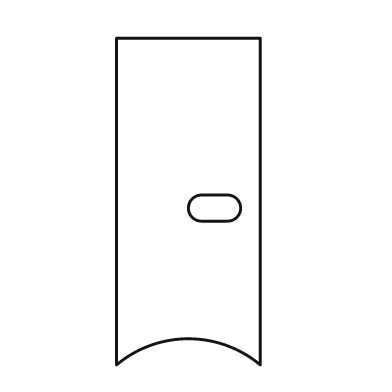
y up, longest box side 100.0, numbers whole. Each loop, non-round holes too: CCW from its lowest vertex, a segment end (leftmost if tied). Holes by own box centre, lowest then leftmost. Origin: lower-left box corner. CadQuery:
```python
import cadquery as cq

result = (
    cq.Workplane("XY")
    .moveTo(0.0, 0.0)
    .threePointArc((22.0, 8.0), (44.0, 0.0))
    .lineTo(44.0, 100.0)
    .lineTo(0.0, 100.0)
    .close()
    .moveTo(26.0, 44.0)
    .lineTo(34.0, 44.0)
    .threePointArc((38.0, 48.0), (34.0, 52.0))
    .lineTo(26.0, 52.0)
    .threePointArc((22.0, 48.0), (26.0, 44.0))
    .close()
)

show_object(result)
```